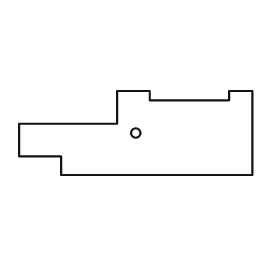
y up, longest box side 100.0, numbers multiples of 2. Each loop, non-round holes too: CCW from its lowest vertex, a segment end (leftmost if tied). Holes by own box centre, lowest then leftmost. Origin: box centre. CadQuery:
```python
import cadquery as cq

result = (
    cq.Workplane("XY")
    .moveTo(-32.0, -18.0)
    .lineTo(50.0, -18.0)
    .lineTo(50.0, 18.0)
    .lineTo(40.0, 18.0)
    .lineTo(40.0, 14.0)
    .lineTo(6.0, 14.0)
    .lineTo(6.0, 18.0)
    .lineTo(-8.0, 18.0)
    .lineTo(-8.0, 4.0)
    .lineTo(-50.0, 4.0)
    .lineTo(-50.0, -10.0)
    .lineTo(-32.0, -10.0)
    .close()
    .moveTo(0.0, 0.0)
    .circle(2.0)
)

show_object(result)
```